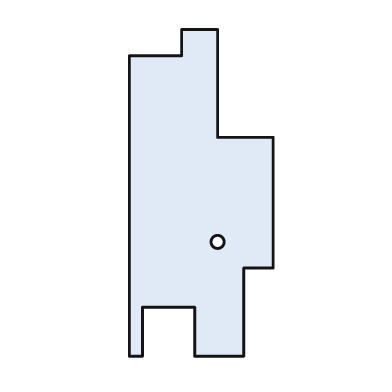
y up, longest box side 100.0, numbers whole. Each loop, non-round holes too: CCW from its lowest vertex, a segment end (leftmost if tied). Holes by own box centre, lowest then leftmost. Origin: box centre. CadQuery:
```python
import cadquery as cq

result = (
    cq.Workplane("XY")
    .moveTo(-22.0, -50.0)
    .lineTo(-18.0, -50.0)
    .lineTo(-18.0, -35.0)
    .lineTo(-2.0, -35.0)
    .lineTo(-2.0, -50.0)
    .lineTo(13.0, -50.0)
    .lineTo(13.0, -23.0)
    .lineTo(22.0, -23.0)
    .lineTo(22.0, 17.0)
    .lineTo(5.0, 17.0)
    .lineTo(5.0, 50.0)
    .lineTo(-6.0, 50.0)
    .lineTo(-6.0, 42.0)
    .lineTo(-22.0, 42.0)
    .close()
    .moveTo(5.0, -15.0)
    .circle(2.0)
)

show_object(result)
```